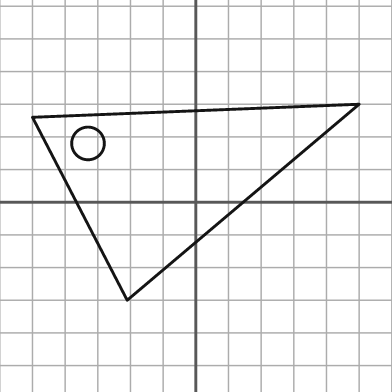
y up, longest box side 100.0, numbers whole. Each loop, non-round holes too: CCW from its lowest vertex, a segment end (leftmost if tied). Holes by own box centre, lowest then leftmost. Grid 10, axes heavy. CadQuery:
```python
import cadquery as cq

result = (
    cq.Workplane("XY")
    .moveTo(-21.0, -30.0)
    .lineTo(50.0, 30.0)
    .lineTo(-50.0, 26.0)
    .close()
    .moveTo(-33.0, 18.0)
    .circle(5.0)
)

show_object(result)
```